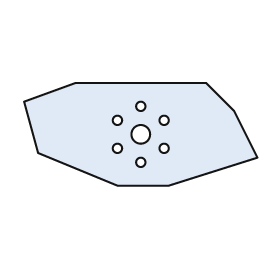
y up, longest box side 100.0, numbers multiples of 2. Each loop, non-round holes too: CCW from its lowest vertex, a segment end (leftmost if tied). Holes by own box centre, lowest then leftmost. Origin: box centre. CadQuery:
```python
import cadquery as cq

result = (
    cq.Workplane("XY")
    .moveTo(-10.0, -22.0)
    .lineTo(12.0, -22.0)
    .lineTo(50.0, -10.0)
    .lineTo(40.0, 10.0)
    .lineTo(28.0, 22.0)
    .lineTo(-28.0, 22.0)
    .lineTo(-50.0, 14.0)
    .lineTo(-44.0, -8.0)
    .close()
    .moveTo(0.0, -12.0)
    .circle(2.0)
    .moveTo(-10.0, -6.0)
    .circle(2.0)
    .moveTo(10.0, -6.0)
    .circle(2.0)
    .moveTo(0.0, 0.0)
    .circle(4.0)
    .moveTo(-10.0, 6.0)
    .circle(2.0)
    .moveTo(10.0, 6.0)
    .circle(2.0)
    .moveTo(0.0, 12.0)
    .circle(2.0)
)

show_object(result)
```